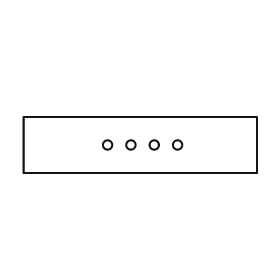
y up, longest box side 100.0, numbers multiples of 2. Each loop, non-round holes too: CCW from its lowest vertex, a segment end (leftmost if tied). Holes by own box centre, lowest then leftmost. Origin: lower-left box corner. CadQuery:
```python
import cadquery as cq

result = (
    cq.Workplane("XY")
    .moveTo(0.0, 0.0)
    .lineTo(100.0, 0.0)
    .lineTo(100.0, 24.0)
    .lineTo(0.0, 24.0)
    .close()
    .moveTo(36.0, 12.0)
    .circle(2.0)
    .moveTo(46.0, 12.0)
    .circle(2.0)
    .moveTo(56.0, 12.0)
    .circle(2.0)
    .moveTo(66.0, 12.0)
    .circle(2.0)
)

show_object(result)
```